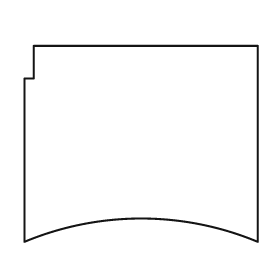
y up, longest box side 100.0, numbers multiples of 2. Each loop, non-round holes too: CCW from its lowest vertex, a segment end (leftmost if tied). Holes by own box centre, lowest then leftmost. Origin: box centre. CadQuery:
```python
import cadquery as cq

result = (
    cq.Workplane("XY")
    .moveTo(-50.0, -42.0)
    .threePointArc((0.0, -32.0), (50.0, -42.0))
    .lineTo(50.0, 42.0)
    .lineTo(-46.0, 42.0)
    .lineTo(-46.0, 28.0)
    .lineTo(-50.0, 28.0)
    .close()
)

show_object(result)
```